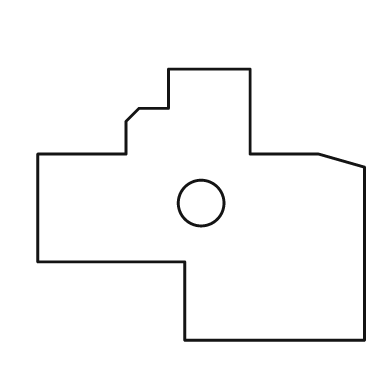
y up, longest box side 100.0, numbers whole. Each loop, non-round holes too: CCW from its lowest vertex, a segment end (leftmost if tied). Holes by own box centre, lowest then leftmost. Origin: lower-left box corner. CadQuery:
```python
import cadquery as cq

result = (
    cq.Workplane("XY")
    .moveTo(45.0, 0.0)
    .lineTo(100.0, 0.0)
    .lineTo(100.0, 53.0)
    .lineTo(86.0, 57.0)
    .lineTo(65.0, 57.0)
    .lineTo(65.0, 83.0)
    .lineTo(40.0, 83.0)
    .lineTo(40.0, 71.0)
    .lineTo(31.0, 71.0)
    .lineTo(27.0, 67.0)
    .lineTo(27.0, 57.0)
    .lineTo(0.0, 57.0)
    .lineTo(0.0, 24.0)
    .lineTo(45.0, 24.0)
    .close()
    .moveTo(50.0, 42.0)
    .circle(7.0)
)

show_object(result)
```